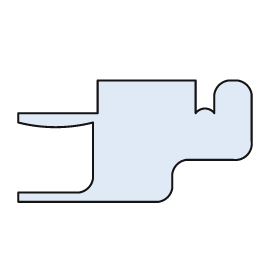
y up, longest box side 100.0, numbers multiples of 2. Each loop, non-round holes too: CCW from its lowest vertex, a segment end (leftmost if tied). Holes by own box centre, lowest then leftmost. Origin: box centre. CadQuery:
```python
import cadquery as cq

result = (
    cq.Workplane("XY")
    .moveTo(-50.0, -26.0)
    .lineTo(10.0, -26.0)
    .threePointArc((14.0, -24.0), (16.0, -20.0))
    .lineTo(16.0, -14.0)
    .threePointArc((18.0, -10.0), (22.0, -8.0))
    .lineTo(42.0, -8.0)
    .threePointArc((48.0, -6.0), (50.0, 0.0))
    .lineTo(50.0, 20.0)
    .threePointArc((48.0, 24.0), (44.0, 26.0))
    .lineTo(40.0, 26.0)
    .threePointArc((36.0, 24.0), (34.0, 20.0))
    .lineTo(34.0, 12.0)
    .threePointArc((30.0, 14.0), (26.0, 12.0))
    .lineTo(26.0, 26.0)
    .lineTo(-16.0, 26.0)
    .lineTo(-16.0, 12.0)
    .lineTo(-50.0, 12.0)
    .lineTo(-50.0, 8.0)
    .threePointArc((-34.0, 6.0), (-18.0, 8.0))
    .lineTo(-18.0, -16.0)
    .threePointArc((-20.0, -20.0), (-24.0, -22.0))
    .lineTo(-50.0, -22.0)
    .close()
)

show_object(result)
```